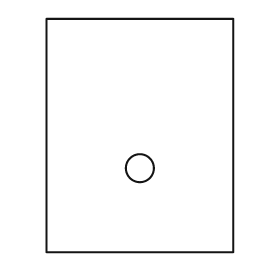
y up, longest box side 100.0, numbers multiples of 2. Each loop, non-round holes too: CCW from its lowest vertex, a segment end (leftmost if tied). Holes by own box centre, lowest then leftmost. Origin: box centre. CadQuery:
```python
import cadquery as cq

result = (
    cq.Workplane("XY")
    .moveTo(-40.0, -50.0)
    .lineTo(40.0, -50.0)
    .lineTo(40.0, 50.0)
    .lineTo(-40.0, 50.0)
    .close()
    .moveTo(0.0, -14.0)
    .circle(6.0)
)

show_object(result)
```